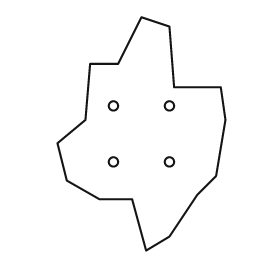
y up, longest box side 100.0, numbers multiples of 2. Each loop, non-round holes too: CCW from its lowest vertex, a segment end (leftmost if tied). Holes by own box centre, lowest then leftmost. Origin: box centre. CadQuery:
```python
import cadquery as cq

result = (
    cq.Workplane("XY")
    .moveTo(2.0, -50.0)
    .lineTo(12.0, -44.0)
    .lineTo(24.0, -26.0)
    .lineTo(32.0, -18.0)
    .lineTo(36.0, 6.0)
    .lineTo(34.0, 20.0)
    .lineTo(14.0, 20.0)
    .lineTo(12.0, 46.0)
    .lineTo(0.0, 50.0)
    .lineTo(-10.0, 30.0)
    .lineTo(-22.0, 30.0)
    .lineTo(-24.0, 6.0)
    .lineTo(-36.0, -4.0)
    .lineTo(-32.0, -20.0)
    .lineTo(-18.0, -28.0)
    .lineTo(-4.0, -28.0)
    .close()
    .moveTo(-12.0, -12.0)
    .circle(2.0)
    .moveTo(12.0, -12.0)
    .circle(2.0)
    .moveTo(-12.0, 12.0)
    .circle(2.0)
    .moveTo(12.0, 12.0)
    .circle(2.0)
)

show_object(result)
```